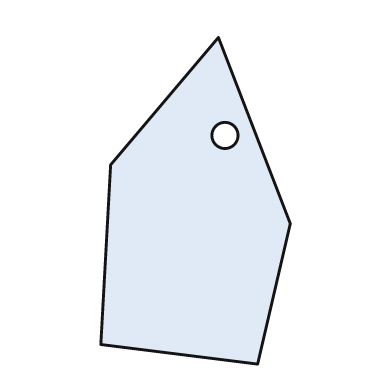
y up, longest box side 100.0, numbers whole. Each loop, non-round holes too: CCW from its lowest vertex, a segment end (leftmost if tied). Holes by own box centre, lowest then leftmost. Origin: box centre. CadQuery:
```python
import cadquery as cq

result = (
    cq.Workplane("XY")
    .moveTo(19.0, -50.0)
    .lineTo(29.0, -7.0)
    .lineTo(7.0, 50.0)
    .lineTo(-26.0, 11.0)
    .lineTo(-29.0, -44.0)
    .close()
    .moveTo(9.0, 20.0)
    .circle(4.0)
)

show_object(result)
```